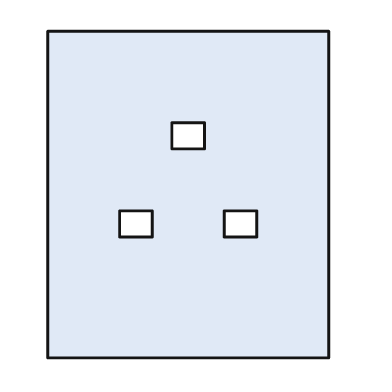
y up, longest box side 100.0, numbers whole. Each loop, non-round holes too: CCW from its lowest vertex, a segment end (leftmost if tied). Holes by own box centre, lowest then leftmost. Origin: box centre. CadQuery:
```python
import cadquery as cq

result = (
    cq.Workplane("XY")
    .moveTo(-43.0, -50.0)
    .lineTo(43.0, -50.0)
    .lineTo(43.0, 50.0)
    .lineTo(-43.0, 50.0)
    .close()
    .moveTo(-21.0, -13.0)
    .lineTo(-11.0, -13.0)
    .lineTo(-11.0, -5.0)
    .lineTo(-21.0, -5.0)
    .close()
    .moveTo(11.0, -13.0)
    .lineTo(21.0, -13.0)
    .lineTo(21.0, -5.0)
    .lineTo(11.0, -5.0)
    .close()
    .moveTo(-5.0, 14.0)
    .lineTo(5.0, 14.0)
    .lineTo(5.0, 22.0)
    .lineTo(-5.0, 22.0)
    .close()
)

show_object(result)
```